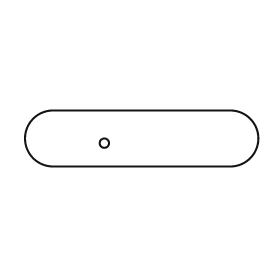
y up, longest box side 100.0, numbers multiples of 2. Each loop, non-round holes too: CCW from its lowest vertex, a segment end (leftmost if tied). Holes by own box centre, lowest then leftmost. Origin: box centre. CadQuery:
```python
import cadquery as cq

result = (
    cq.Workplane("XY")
    .moveTo(-38.0, -12.0)
    .lineTo(38.0, -12.0)
    .threePointArc((50.0, 0.0), (38.0, 12.0))
    .lineTo(-38.0, 12.0)
    .threePointArc((-50.0, 0.0), (-38.0, -12.0))
    .close()
    .moveTo(-16.0, -2.0)
    .circle(2.0)
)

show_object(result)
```